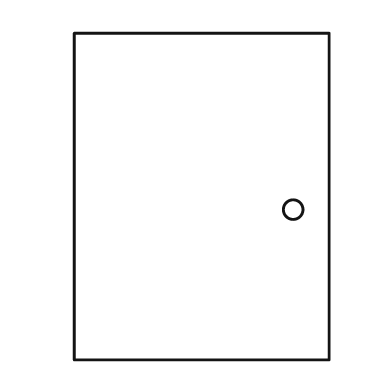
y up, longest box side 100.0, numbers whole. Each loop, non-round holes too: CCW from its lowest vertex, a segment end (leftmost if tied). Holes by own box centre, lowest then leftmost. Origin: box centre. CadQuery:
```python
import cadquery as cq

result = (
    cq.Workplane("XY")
    .moveTo(-39.0, -50.0)
    .lineTo(39.0, -50.0)
    .lineTo(39.0, 50.0)
    .lineTo(-39.0, 50.0)
    .close()
    .moveTo(28.0, -4.0)
    .circle(3.0)
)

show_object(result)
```